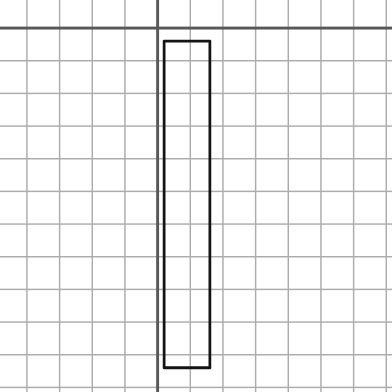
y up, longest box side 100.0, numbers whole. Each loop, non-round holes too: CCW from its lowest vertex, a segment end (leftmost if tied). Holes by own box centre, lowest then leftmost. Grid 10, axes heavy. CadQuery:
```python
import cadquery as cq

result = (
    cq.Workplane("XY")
    .moveTo(2.0, -104.0)
    .lineTo(16.0, -104.0)
    .lineTo(16.0, -4.0)
    .lineTo(2.0, -4.0)
    .close()
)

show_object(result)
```